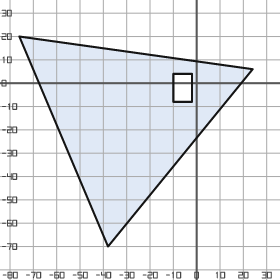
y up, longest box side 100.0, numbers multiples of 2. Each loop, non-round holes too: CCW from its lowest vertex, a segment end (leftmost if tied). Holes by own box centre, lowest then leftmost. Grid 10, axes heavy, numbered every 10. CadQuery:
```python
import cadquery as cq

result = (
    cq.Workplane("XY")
    .moveTo(-38.0, -70.0)
    .lineTo(24.0, 6.0)
    .lineTo(-76.0, 20.0)
    .close()
    .moveTo(-10.0, -8.0)
    .lineTo(-2.0, -8.0)
    .lineTo(-2.0, 4.0)
    .lineTo(-10.0, 4.0)
    .close()
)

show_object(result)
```